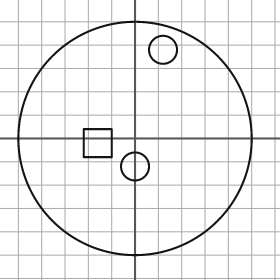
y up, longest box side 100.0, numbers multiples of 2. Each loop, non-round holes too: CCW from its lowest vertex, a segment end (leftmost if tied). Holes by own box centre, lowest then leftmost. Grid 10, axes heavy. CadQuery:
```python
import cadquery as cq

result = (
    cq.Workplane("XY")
    .moveTo(0.0, 0.0)
    .circle(50.0)
    .moveTo(0.0, -12.0)
    .circle(6.0)
    .moveTo(-22.0, -8.0)
    .lineTo(-10.0, -8.0)
    .lineTo(-10.0, 4.0)
    .lineTo(-22.0, 4.0)
    .close()
    .moveTo(12.0, 38.0)
    .circle(6.0)
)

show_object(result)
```